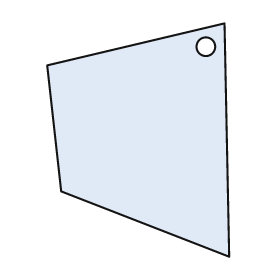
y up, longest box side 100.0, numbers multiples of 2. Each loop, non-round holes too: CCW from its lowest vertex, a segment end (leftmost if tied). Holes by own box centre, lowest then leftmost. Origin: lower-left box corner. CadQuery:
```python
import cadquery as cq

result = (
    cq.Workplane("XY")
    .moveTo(78.0, 0.0)
    .lineTo(76.0, 100.0)
    .lineTo(0.0, 82.0)
    .lineTo(6.0, 28.0)
    .close()
    .moveTo(68.0, 90.0)
    .circle(4.0)
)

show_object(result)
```